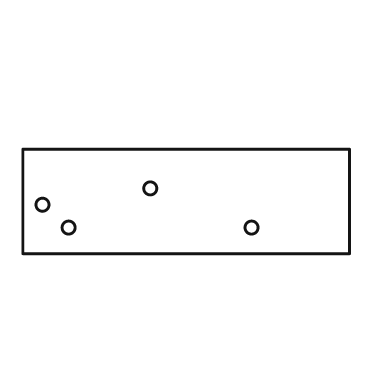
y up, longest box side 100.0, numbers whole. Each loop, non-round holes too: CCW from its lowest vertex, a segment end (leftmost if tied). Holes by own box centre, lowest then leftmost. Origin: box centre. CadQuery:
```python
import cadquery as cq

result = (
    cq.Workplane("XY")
    .moveTo(-50.0, -16.0)
    .lineTo(50.0, -16.0)
    .lineTo(50.0, 16.0)
    .lineTo(-50.0, 16.0)
    .close()
    .moveTo(-36.0, -8.0)
    .circle(2.0)
    .moveTo(20.0, -8.0)
    .circle(2.0)
    .moveTo(-44.0, -1.0)
    .circle(2.0)
    .moveTo(-11.0, 4.0)
    .circle(2.0)
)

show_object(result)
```